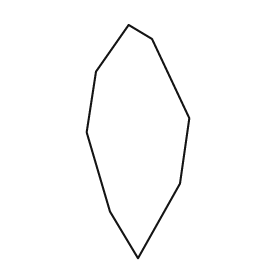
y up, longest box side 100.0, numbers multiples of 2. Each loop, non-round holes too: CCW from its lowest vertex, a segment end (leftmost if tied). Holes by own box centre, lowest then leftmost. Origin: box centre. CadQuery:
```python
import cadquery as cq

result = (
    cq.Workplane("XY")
    .moveTo(0.0, -50.0)
    .lineTo(18.0, -18.0)
    .lineTo(22.0, 10.0)
    .lineTo(6.0, 44.0)
    .lineTo(-4.0, 50.0)
    .lineTo(-18.0, 30.0)
    .lineTo(-22.0, 4.0)
    .lineTo(-12.0, -30.0)
    .close()
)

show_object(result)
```